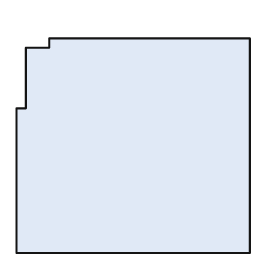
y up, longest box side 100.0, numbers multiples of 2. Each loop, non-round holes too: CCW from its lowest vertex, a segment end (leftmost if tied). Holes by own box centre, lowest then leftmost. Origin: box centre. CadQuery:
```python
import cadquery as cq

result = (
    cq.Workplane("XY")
    .moveTo(-50.0, -46.0)
    .lineTo(50.0, -46.0)
    .lineTo(50.0, 46.0)
    .lineTo(-36.0, 46.0)
    .lineTo(-36.0, 42.0)
    .lineTo(-46.0, 42.0)
    .lineTo(-46.0, 16.0)
    .lineTo(-50.0, 16.0)
    .close()
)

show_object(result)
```